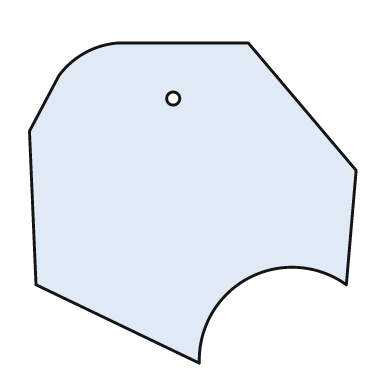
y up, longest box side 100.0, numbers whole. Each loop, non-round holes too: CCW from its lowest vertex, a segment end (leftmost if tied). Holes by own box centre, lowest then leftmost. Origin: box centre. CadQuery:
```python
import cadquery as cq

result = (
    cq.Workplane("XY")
    .moveTo(2.0, -49.0)
    .threePointArc((17.0, -23.0), (47.0, -25.0))
    .lineTo(50.0, 10.0)
    .lineTo(17.0, 49.0)
    .lineTo(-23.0, 49.0)
    .threePointArc((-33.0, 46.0), (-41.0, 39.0))
    .lineTo(-50.0, 22.0)
    .lineTo(-48.0, -25.0)
    .close()
    .moveTo(-6.0, 32.0)
    .circle(2.0)
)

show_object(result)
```